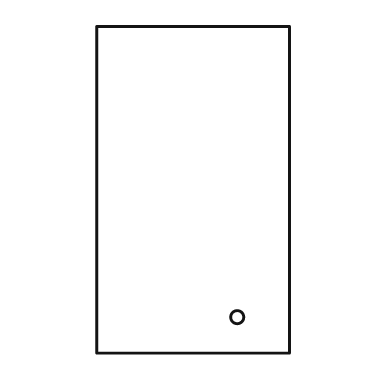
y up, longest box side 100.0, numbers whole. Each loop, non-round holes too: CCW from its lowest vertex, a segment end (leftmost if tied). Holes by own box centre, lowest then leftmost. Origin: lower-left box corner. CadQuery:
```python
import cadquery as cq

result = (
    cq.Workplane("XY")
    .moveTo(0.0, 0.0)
    .lineTo(59.0, 0.0)
    .lineTo(59.0, 100.0)
    .lineTo(0.0, 100.0)
    .close()
    .moveTo(43.0, 11.0)
    .circle(2.0)
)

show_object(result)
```